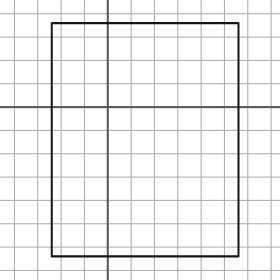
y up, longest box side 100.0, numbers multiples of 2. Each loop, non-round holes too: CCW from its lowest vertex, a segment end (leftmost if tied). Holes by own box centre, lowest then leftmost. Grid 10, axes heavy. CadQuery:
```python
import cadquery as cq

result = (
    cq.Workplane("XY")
    .moveTo(-24.0, -64.0)
    .lineTo(56.0, -64.0)
    .lineTo(56.0, 36.0)
    .lineTo(-24.0, 36.0)
    .close()
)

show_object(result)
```